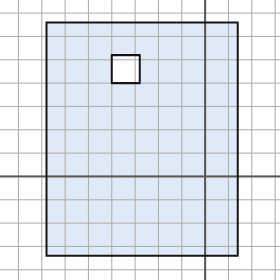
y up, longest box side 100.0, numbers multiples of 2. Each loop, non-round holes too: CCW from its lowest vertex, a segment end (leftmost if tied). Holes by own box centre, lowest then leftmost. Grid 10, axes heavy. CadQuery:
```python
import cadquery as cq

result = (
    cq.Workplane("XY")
    .moveTo(-68.0, -34.0)
    .lineTo(14.0, -34.0)
    .lineTo(14.0, 66.0)
    .lineTo(-68.0, 66.0)
    .close()
    .moveTo(-40.0, 40.0)
    .lineTo(-28.0, 40.0)
    .lineTo(-28.0, 52.0)
    .lineTo(-40.0, 52.0)
    .close()
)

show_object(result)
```